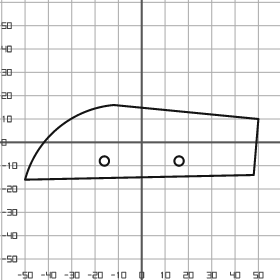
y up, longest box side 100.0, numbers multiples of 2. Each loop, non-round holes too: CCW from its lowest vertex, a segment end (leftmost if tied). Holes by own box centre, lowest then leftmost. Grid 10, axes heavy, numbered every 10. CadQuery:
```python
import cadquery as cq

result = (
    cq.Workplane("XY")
    .moveTo(-50.0, -16.0)
    .lineTo(48.0, -14.0)
    .lineTo(50.0, 10.0)
    .lineTo(-12.0, 16.0)
    .threePointArc((-36.0, 6.0), (-50.0, -16.0))
    .close()
    .moveTo(-16.0, -8.0)
    .circle(2.0)
    .moveTo(16.0, -8.0)
    .circle(2.0)
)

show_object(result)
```